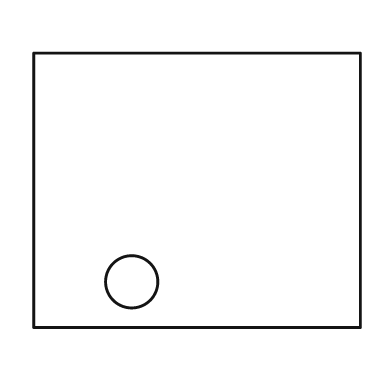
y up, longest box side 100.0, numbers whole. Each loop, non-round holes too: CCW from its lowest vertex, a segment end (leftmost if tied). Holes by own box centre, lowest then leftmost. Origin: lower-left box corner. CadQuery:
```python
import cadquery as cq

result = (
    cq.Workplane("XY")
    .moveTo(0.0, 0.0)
    .lineTo(100.0, 0.0)
    .lineTo(100.0, 84.0)
    .lineTo(0.0, 84.0)
    .close()
    .moveTo(30.0, 14.0)
    .circle(8.0)
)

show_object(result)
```